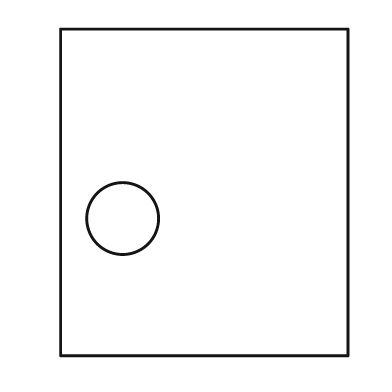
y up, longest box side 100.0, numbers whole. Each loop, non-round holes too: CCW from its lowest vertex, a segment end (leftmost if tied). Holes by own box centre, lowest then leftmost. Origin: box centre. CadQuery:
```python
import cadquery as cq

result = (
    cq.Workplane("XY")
    .moveTo(-44.0, -50.0)
    .lineTo(44.0, -50.0)
    .lineTo(44.0, 50.0)
    .lineTo(-44.0, 50.0)
    .close()
    .moveTo(-25.0, -8.0)
    .circle(11.0)
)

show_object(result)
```